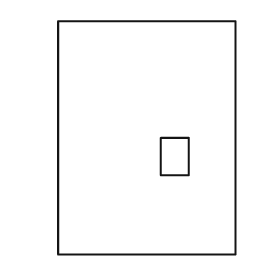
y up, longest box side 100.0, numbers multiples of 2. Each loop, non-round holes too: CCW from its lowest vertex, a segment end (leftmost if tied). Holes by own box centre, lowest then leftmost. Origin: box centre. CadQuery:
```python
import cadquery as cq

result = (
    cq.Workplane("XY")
    .moveTo(-38.0, -50.0)
    .lineTo(38.0, -50.0)
    .lineTo(38.0, 50.0)
    .lineTo(-38.0, 50.0)
    .close()
    .moveTo(6.0, -16.0)
    .lineTo(18.0, -16.0)
    .lineTo(18.0, 0.0)
    .lineTo(6.0, 0.0)
    .close()
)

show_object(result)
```